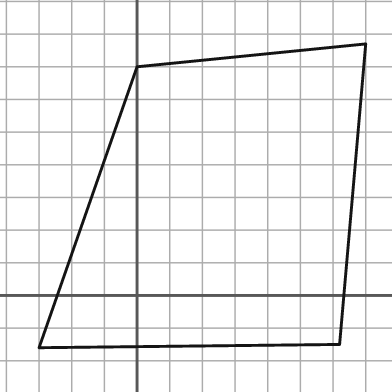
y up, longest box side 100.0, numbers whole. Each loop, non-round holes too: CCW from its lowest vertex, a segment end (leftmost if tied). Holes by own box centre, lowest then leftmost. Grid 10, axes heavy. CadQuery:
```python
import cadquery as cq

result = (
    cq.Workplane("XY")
    .moveTo(-30.0, -16.0)
    .lineTo(62.0, -15.0)
    .lineTo(70.0, 77.0)
    .lineTo(0.0, 70.0)
    .close()
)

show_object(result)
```